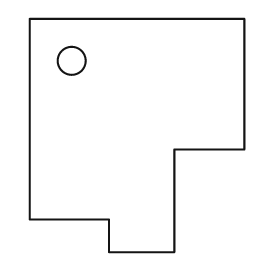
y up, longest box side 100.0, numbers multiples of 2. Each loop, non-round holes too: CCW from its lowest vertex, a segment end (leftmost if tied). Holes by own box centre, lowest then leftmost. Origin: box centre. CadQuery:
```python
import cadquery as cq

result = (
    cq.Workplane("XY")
    .moveTo(-12.0, -50.0)
    .lineTo(16.0, -50.0)
    .lineTo(16.0, -6.0)
    .lineTo(46.0, -6.0)
    .lineTo(46.0, 50.0)
    .lineTo(-46.0, 50.0)
    .lineTo(-46.0, -36.0)
    .lineTo(-12.0, -36.0)
    .close()
    .moveTo(-28.0, 32.0)
    .circle(6.0)
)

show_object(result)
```